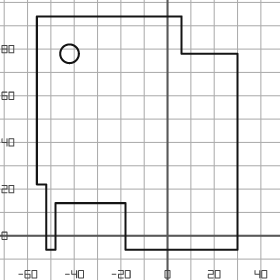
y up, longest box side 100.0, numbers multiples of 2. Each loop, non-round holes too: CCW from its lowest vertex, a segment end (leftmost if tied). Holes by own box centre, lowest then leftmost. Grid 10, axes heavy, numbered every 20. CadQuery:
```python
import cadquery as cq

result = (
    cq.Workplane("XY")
    .moveTo(-52.0, -6.0)
    .lineTo(-48.0, -6.0)
    .lineTo(-48.0, 14.0)
    .lineTo(-18.0, 14.0)
    .lineTo(-18.0, -6.0)
    .lineTo(30.0, -6.0)
    .lineTo(30.0, 78.0)
    .lineTo(6.0, 78.0)
    .lineTo(6.0, 94.0)
    .lineTo(-56.0, 94.0)
    .lineTo(-56.0, 22.0)
    .lineTo(-52.0, 22.0)
    .close()
    .moveTo(-42.0, 78.0)
    .circle(4.0)
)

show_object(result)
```